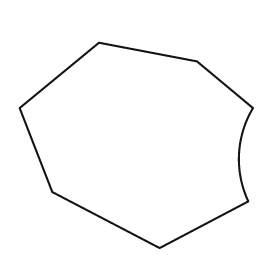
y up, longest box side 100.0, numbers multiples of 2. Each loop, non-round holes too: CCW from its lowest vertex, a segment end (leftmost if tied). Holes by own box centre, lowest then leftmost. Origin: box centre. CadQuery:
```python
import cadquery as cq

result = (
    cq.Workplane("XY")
    .moveTo(10.0, -44.0)
    .lineTo(48.0, -24.0)
    .threePointArc((44.0, -4.0), (50.0, 16.0))
    .lineTo(26.0, 36.0)
    .lineTo(-16.0, 44.0)
    .lineTo(-50.0, 16.0)
    .lineTo(-36.0, -20.0)
    .close()
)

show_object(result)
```